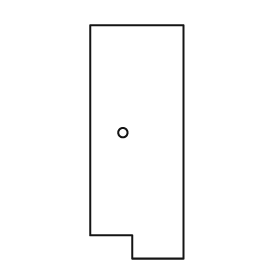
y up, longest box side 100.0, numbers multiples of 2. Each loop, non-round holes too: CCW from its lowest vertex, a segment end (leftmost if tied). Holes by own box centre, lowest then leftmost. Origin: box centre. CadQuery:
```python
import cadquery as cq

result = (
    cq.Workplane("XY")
    .moveTo(-2.0, -50.0)
    .lineTo(20.0, -50.0)
    .lineTo(20.0, 50.0)
    .lineTo(-20.0, 50.0)
    .lineTo(-20.0, -40.0)
    .lineTo(-2.0, -40.0)
    .close()
    .moveTo(-6.0, 4.0)
    .circle(2.0)
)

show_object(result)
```